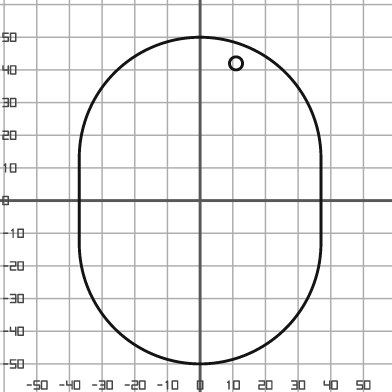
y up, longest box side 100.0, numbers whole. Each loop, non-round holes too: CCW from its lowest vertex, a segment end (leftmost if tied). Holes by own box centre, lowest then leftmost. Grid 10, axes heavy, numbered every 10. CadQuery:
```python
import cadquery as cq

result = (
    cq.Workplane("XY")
    .moveTo(-37.0, -13.0)
    .threePointArc((0.0, -50.0), (37.0, -13.0))
    .lineTo(37.0, 13.0)
    .threePointArc((0.0, 50.0), (-37.0, 13.0))
    .close()
    .moveTo(11.0, 42.0)
    .circle(2.0)
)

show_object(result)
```